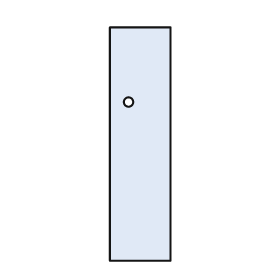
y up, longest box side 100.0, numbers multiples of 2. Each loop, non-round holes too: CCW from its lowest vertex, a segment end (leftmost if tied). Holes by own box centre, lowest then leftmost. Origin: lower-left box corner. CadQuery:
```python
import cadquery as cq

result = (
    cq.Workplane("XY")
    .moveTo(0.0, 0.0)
    .lineTo(26.0, 0.0)
    .lineTo(26.0, 100.0)
    .lineTo(0.0, 100.0)
    .close()
    .moveTo(8.0, 68.0)
    .circle(2.0)
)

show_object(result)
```